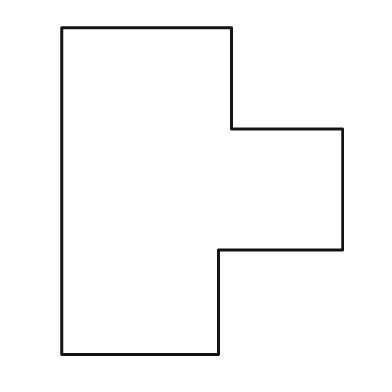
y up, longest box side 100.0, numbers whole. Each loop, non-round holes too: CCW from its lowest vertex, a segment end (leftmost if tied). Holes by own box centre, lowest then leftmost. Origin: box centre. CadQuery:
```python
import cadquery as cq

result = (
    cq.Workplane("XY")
    .moveTo(-43.0, -50.0)
    .lineTo(5.0, -50.0)
    .lineTo(5.0, -18.0)
    .lineTo(43.0, -18.0)
    .lineTo(43.0, 19.0)
    .lineTo(9.0, 19.0)
    .lineTo(9.0, 50.0)
    .lineTo(-43.0, 50.0)
    .close()
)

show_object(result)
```